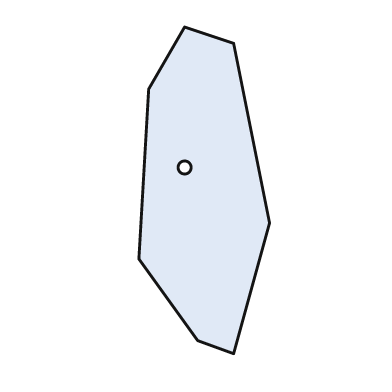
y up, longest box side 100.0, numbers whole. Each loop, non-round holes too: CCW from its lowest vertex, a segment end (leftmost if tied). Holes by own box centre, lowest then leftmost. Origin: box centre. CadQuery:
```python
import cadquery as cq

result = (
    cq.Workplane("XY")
    .moveTo(9.0, -50.0)
    .lineTo(20.0, -10.0)
    .lineTo(9.0, 45.0)
    .lineTo(-6.0, 50.0)
    .lineTo(-17.0, 31.0)
    .lineTo(-20.0, -21.0)
    .lineTo(-2.0, -46.0)
    .close()
    .moveTo(-6.0, 7.0)
    .circle(2.0)
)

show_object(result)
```